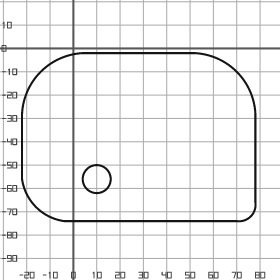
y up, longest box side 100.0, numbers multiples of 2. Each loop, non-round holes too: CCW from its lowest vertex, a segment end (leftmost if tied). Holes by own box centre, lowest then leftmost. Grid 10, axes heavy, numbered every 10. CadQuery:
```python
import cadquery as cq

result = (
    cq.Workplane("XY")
    .moveTo(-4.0, -74.0)
    .lineTo(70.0, -74.0)
    .threePointArc((76.0, -72.0), (78.0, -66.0))
    .lineTo(78.0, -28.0)
    .threePointArc((70.0, -10.0), (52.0, -2.0))
    .lineTo(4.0, -2.0)
    .threePointArc((-14.0, -10.0), (-22.0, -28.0))
    .lineTo(-22.0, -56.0)
    .threePointArc((-16.0, -68.0), (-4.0, -74.0))
    .close()
    .moveTo(10.0, -56.0)
    .circle(6.0)
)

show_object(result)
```